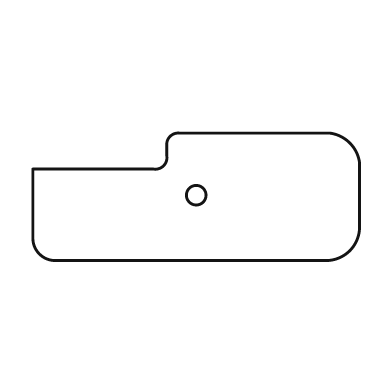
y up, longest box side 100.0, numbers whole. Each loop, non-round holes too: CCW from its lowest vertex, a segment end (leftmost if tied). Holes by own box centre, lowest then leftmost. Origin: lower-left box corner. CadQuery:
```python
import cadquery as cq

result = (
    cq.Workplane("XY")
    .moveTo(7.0, 0.0)
    .lineTo(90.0, 0.0)
    .threePointArc((97.0, 3.0), (100.0, 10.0))
    .lineTo(100.0, 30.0)
    .threePointArc((97.0, 36.0), (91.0, 39.0))
    .lineTo(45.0, 39.0)
    .threePointArc((42.0, 38.0), (41.0, 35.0))
    .lineTo(41.0, 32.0)
    .threePointArc((40.0, 29.0), (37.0, 28.0))
    .lineTo(0.0, 28.0)
    .lineTo(0.0, 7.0)
    .threePointArc((2.0, 2.0), (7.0, 0.0))
    .close()
    .moveTo(50.0, 20.0)
    .circle(3.0)
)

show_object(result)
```